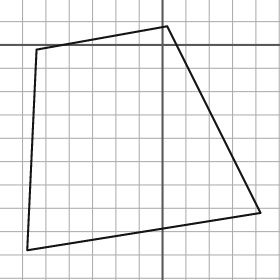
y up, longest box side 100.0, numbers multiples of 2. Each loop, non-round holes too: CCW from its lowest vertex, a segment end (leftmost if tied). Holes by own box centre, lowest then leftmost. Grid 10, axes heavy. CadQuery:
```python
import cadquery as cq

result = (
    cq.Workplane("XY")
    .moveTo(-58.0, -88.0)
    .lineTo(42.0, -72.0)
    .lineTo(2.0, 8.0)
    .lineTo(-54.0, -2.0)
    .close()
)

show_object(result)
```